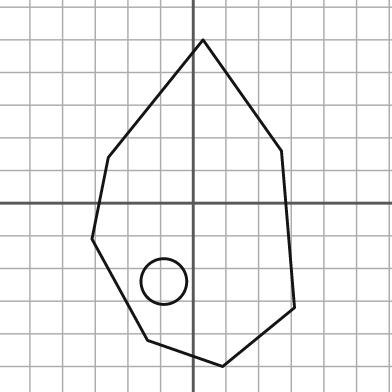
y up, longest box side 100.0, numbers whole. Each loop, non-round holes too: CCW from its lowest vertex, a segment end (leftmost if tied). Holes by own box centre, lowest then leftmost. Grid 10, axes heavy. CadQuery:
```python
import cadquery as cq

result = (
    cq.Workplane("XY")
    .moveTo(9.0, -50.0)
    .lineTo(31.0, -32.0)
    .lineTo(27.0, 16.0)
    .lineTo(3.0, 50.0)
    .lineTo(-26.0, 14.0)
    .lineTo(-31.0, -11.0)
    .lineTo(-14.0, -42.0)
    .close()
    .moveTo(-9.0, -24.0)
    .circle(7.0)
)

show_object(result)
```